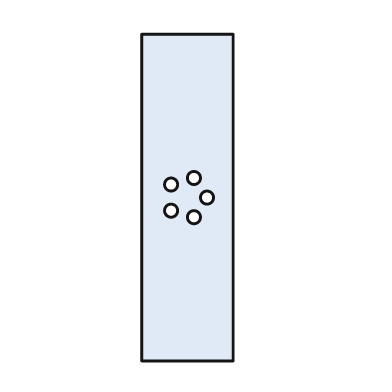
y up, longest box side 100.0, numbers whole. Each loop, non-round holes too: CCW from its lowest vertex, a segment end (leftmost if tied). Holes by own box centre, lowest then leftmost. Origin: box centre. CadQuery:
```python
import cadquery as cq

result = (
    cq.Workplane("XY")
    .moveTo(-14.0, -50.0)
    .lineTo(14.0, -50.0)
    .lineTo(14.0, 50.0)
    .lineTo(-14.0, 50.0)
    .close()
    .moveTo(2.0, -6.0)
    .circle(2.0)
    .moveTo(-5.0, -4.0)
    .circle(2.0)
    .moveTo(6.0, 0.0)
    .circle(2.0)
    .moveTo(-5.0, 4.0)
    .circle(2.0)
    .moveTo(2.0, 6.0)
    .circle(2.0)
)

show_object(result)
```